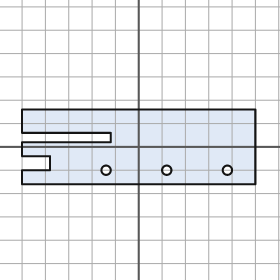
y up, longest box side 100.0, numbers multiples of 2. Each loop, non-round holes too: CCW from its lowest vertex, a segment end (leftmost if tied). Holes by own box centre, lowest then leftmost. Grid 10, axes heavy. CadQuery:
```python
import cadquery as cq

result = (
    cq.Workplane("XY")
    .moveTo(-50.0, -16.0)
    .lineTo(50.0, -16.0)
    .lineTo(50.0, 16.0)
    .lineTo(-50.0, 16.0)
    .lineTo(-50.0, 6.0)
    .lineTo(-12.0, 6.0)
    .lineTo(-12.0, 2.0)
    .lineTo(-50.0, 2.0)
    .lineTo(-50.0, -4.0)
    .lineTo(-38.0, -4.0)
    .lineTo(-38.0, -10.0)
    .lineTo(-50.0, -10.0)
    .close()
    .moveTo(-14.0, -10.0)
    .circle(2.0)
    .moveTo(12.0, -10.0)
    .circle(2.0)
    .moveTo(38.0, -10.0)
    .circle(2.0)
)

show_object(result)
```